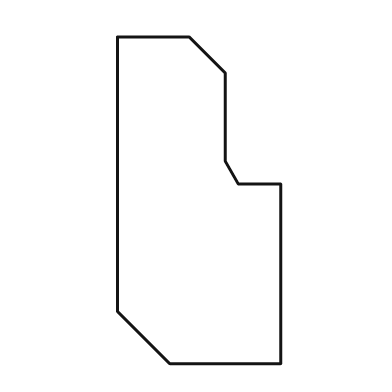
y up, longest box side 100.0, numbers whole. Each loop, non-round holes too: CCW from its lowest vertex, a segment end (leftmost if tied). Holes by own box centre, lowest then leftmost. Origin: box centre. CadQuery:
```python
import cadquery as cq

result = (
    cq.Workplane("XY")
    .moveTo(-9.0, -50.0)
    .lineTo(25.0, -50.0)
    .lineTo(25.0, 5.0)
    .lineTo(12.0, 5.0)
    .lineTo(8.0, 12.0)
    .lineTo(8.0, 39.0)
    .lineTo(-3.0, 50.0)
    .lineTo(-25.0, 50.0)
    .lineTo(-25.0, -34.0)
    .close()
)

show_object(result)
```